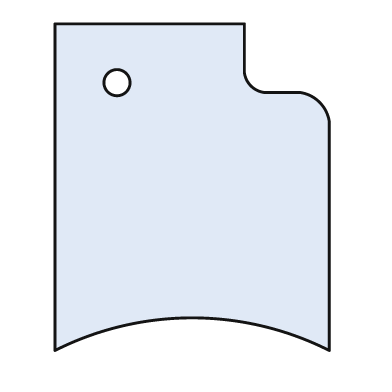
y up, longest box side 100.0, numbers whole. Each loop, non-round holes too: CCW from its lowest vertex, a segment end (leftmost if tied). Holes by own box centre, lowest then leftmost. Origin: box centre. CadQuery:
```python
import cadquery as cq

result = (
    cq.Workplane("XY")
    .moveTo(-42.0, -50.0)
    .threePointArc((0.0, -40.0), (42.0, -50.0))
    .lineTo(42.0, 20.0)
    .threePointArc((39.0, 26.0), (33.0, 29.0))
    .lineTo(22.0, 29.0)
    .threePointArc((18.0, 31.0), (16.0, 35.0))
    .lineTo(16.0, 50.0)
    .lineTo(-42.0, 50.0)
    .close()
    .moveTo(-23.0, 32.0)
    .circle(4.0)
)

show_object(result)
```